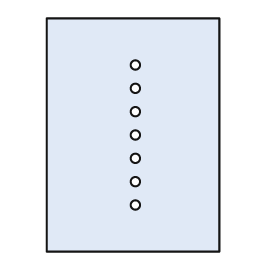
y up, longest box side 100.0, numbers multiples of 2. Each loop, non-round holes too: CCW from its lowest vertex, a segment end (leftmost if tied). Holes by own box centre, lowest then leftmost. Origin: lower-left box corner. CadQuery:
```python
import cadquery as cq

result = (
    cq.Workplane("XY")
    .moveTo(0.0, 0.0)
    .lineTo(74.0, 0.0)
    .lineTo(74.0, 100.0)
    .lineTo(0.0, 100.0)
    .close()
    .moveTo(38.0, 20.0)
    .circle(2.0)
    .moveTo(38.0, 30.0)
    .circle(2.0)
    .moveTo(38.0, 40.0)
    .circle(2.0)
    .moveTo(38.0, 50.0)
    .circle(2.0)
    .moveTo(38.0, 60.0)
    .circle(2.0)
    .moveTo(38.0, 70.0)
    .circle(2.0)
    .moveTo(38.0, 80.0)
    .circle(2.0)
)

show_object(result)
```